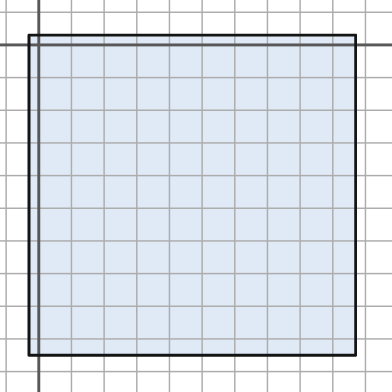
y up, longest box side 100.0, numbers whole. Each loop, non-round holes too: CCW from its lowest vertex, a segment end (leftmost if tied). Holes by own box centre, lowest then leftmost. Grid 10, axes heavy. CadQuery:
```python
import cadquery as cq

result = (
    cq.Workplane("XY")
    .moveTo(-3.0, -95.0)
    .lineTo(97.0, -95.0)
    .lineTo(97.0, 3.0)
    .lineTo(-3.0, 3.0)
    .close()
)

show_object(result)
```